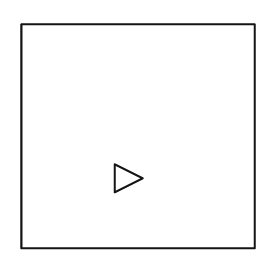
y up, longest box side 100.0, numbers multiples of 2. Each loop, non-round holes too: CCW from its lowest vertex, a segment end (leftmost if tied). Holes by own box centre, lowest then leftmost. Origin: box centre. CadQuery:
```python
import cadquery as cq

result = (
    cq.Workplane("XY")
    .moveTo(-50.0, -48.0)
    .lineTo(50.0, -48.0)
    .lineTo(50.0, 48.0)
    .lineTo(-50.0, 48.0)
    .close()
    .moveTo(-10.0, -24.0)
    .lineTo(2.0, -18.0)
    .lineTo(-10.0, -12.0)
    .close()
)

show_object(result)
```